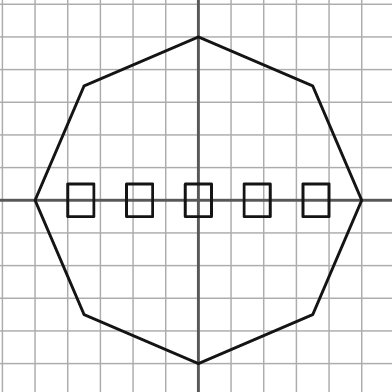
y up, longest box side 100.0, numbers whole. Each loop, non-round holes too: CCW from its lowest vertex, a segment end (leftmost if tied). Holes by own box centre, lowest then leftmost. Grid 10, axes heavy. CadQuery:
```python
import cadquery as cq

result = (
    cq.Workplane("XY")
    .moveTo(0.0, -50.0)
    .lineTo(35.0, -35.0)
    .lineTo(50.0, 0.0)
    .lineTo(35.0, 35.0)
    .lineTo(0.0, 50.0)
    .lineTo(-35.0, 35.0)
    .lineTo(-50.0, 0.0)
    .lineTo(-35.0, -35.0)
    .close()
    .moveTo(-40.0, -5.0)
    .lineTo(-32.0, -5.0)
    .lineTo(-32.0, 5.0)
    .lineTo(-40.0, 5.0)
    .close()
    .moveTo(-22.0, -5.0)
    .lineTo(-14.0, -5.0)
    .lineTo(-14.0, 5.0)
    .lineTo(-22.0, 5.0)
    .close()
    .moveTo(-4.0, -5.0)
    .lineTo(4.0, -5.0)
    .lineTo(4.0, 5.0)
    .lineTo(-4.0, 5.0)
    .close()
    .moveTo(14.0, -5.0)
    .lineTo(22.0, -5.0)
    .lineTo(22.0, 5.0)
    .lineTo(14.0, 5.0)
    .close()
    .moveTo(32.0, -5.0)
    .lineTo(40.0, -5.0)
    .lineTo(40.0, 5.0)
    .lineTo(32.0, 5.0)
    .close()
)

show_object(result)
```